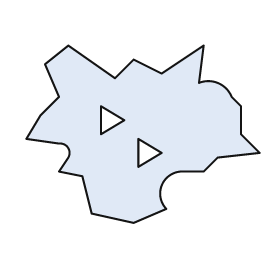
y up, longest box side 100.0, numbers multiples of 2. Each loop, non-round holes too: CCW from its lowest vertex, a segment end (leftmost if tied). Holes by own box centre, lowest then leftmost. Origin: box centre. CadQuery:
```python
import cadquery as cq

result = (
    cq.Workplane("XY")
    .moveTo(-4.0, -38.0)
    .lineTo(10.0, -32.0)
    .threePointArc((8.0, -22.0), (16.0, -16.0))
    .lineTo(26.0, -16.0)
    .lineTo(32.0, -10.0)
    .lineTo(50.0, -8.0)
    .lineTo(42.0, 0.0)
    .lineTo(42.0, 12.0)
    .lineTo(38.0, 16.0)
    .threePointArc((32.0, 22.0), (24.0, 22.0))
    .lineTo(26.0, 38.0)
    .lineTo(8.0, 26.0)
    .lineTo(-4.0, 32.0)
    .lineTo(-12.0, 24.0)
    .lineTo(-32.0, 38.0)
    .lineTo(-42.0, 30.0)
    .lineTo(-36.0, 16.0)
    .lineTo(-44.0, 8.0)
    .lineTo(-50.0, -2.0)
    .lineTo(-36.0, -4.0)
    .threePointArc((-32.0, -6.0), (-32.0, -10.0))
    .lineTo(-36.0, -16.0)
    .lineTo(-26.0, -18.0)
    .lineTo(-22.0, -34.0)
    .close()
    .moveTo(-2.0, -14.0)
    .lineTo(8.0, -8.0)
    .lineTo(-2.0, -2.0)
    .close()
    .moveTo(-18.0, 0.0)
    .lineTo(-8.0, 6.0)
    .lineTo(-18.0, 12.0)
    .close()
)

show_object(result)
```